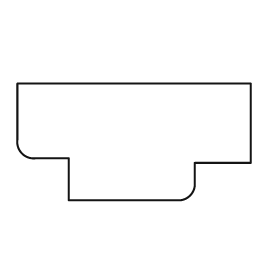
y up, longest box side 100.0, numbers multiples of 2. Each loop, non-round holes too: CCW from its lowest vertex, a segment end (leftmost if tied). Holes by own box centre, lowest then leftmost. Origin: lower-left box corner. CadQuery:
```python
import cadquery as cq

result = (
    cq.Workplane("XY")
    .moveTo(22.0, 0.0)
    .lineTo(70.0, 0.0)
    .threePointArc((74.0, 2.0), (76.0, 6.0))
    .lineTo(76.0, 16.0)
    .lineTo(100.0, 16.0)
    .lineTo(100.0, 50.0)
    .lineTo(0.0, 50.0)
    .lineTo(0.0, 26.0)
    .threePointArc((2.0, 20.0), (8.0, 18.0))
    .lineTo(22.0, 18.0)
    .close()
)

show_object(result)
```